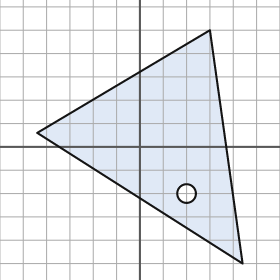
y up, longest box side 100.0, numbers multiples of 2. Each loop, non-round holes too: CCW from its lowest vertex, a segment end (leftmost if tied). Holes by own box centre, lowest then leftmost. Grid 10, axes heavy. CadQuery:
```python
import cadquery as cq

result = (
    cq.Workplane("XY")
    .moveTo(44.0, -50.0)
    .lineTo(30.0, 50.0)
    .lineTo(-44.0, 6.0)
    .close()
    .moveTo(20.0, -20.0)
    .circle(4.0)
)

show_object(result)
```